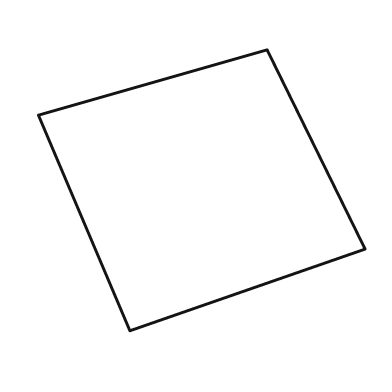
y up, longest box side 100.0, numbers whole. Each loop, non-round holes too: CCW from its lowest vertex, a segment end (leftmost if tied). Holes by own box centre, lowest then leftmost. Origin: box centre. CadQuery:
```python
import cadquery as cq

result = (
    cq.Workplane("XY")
    .moveTo(-22.0, -43.0)
    .lineTo(50.0, -18.0)
    .lineTo(20.0, 43.0)
    .lineTo(-50.0, 23.0)
    .close()
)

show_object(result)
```